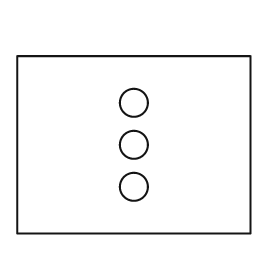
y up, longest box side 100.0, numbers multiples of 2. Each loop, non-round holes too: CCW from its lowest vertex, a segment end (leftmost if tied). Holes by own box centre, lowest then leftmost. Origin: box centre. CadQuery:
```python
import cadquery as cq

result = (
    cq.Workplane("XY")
    .moveTo(-50.0, -38.0)
    .lineTo(50.0, -38.0)
    .lineTo(50.0, 38.0)
    .lineTo(-50.0, 38.0)
    .close()
    .moveTo(0.0, -18.0)
    .circle(6.0)
    .moveTo(0.0, 0.0)
    .circle(6.0)
    .moveTo(0.0, 18.0)
    .circle(6.0)
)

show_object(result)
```